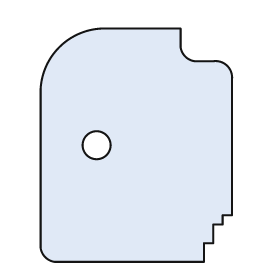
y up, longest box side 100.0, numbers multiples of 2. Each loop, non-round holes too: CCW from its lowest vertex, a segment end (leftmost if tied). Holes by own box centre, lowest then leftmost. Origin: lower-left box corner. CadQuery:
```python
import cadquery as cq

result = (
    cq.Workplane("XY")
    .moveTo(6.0, 0.0)
    .lineTo(70.0, 0.0)
    .lineTo(70.0, 8.0)
    .lineTo(74.0, 8.0)
    .lineTo(74.0, 16.0)
    .lineTo(78.0, 16.0)
    .lineTo(78.0, 20.0)
    .lineTo(82.0, 20.0)
    .lineTo(82.0, 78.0)
    .threePointArc((80.0, 84.0), (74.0, 86.0))
    .lineTo(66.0, 86.0)
    .threePointArc((62.0, 88.0), (60.0, 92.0))
    .lineTo(60.0, 100.0)
    .lineTo(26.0, 100.0)
    .threePointArc((8.0, 92.0), (0.0, 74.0))
    .lineTo(0.0, 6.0)
    .threePointArc((2.0, 2.0), (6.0, 0.0))
    .close()
    .moveTo(24.0, 50.0)
    .circle(6.0)
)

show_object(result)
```